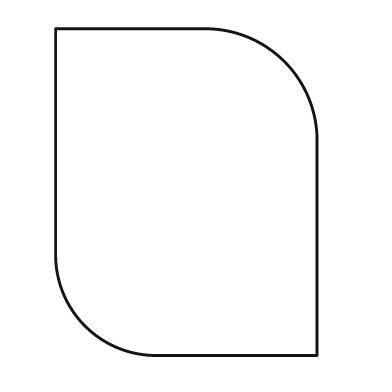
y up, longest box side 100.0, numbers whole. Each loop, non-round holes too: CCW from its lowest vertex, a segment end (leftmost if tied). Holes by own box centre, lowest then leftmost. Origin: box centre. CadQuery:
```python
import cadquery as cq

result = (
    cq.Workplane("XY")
    .moveTo(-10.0, -50.0)
    .lineTo(40.0, -50.0)
    .lineTo(40.0, 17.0)
    .threePointArc((30.0, 40.0), (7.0, 50.0))
    .lineTo(-40.0, 50.0)
    .lineTo(-40.0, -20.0)
    .threePointArc((-31.0, -41.0), (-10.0, -50.0))
    .close()
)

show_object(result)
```